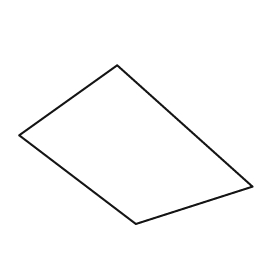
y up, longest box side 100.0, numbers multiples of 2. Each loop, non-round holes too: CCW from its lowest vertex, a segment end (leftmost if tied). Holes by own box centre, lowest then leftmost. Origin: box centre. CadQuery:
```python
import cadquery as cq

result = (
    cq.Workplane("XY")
    .moveTo(0.0, -34.0)
    .lineTo(50.0, -18.0)
    .lineTo(-8.0, 34.0)
    .lineTo(-50.0, 4.0)
    .close()
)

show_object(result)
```